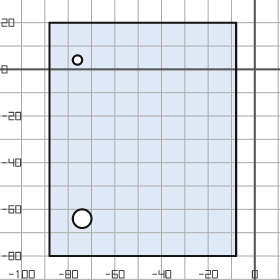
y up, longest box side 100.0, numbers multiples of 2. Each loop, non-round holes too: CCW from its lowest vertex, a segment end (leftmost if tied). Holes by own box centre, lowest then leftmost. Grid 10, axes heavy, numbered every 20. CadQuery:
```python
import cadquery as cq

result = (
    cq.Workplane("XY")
    .moveTo(-88.0, -80.0)
    .lineTo(-8.0, -80.0)
    .lineTo(-8.0, 20.0)
    .lineTo(-88.0, 20.0)
    .close()
    .moveTo(-74.0, -64.0)
    .circle(4.0)
    .moveTo(-76.0, 4.0)
    .circle(2.0)
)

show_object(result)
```